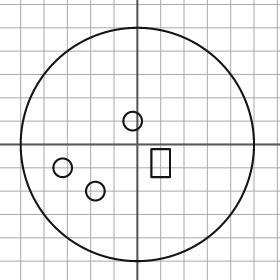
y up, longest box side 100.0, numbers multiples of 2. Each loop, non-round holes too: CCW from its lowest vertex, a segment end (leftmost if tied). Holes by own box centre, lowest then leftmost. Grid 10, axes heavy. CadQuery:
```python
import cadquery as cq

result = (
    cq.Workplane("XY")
    .moveTo(0.0, 0.0)
    .circle(50.0)
    .moveTo(-18.0, -20.0)
    .circle(4.0)
    .moveTo(-32.0, -10.0)
    .circle(4.0)
    .moveTo(6.0, -14.0)
    .lineTo(14.0, -14.0)
    .lineTo(14.0, -2.0)
    .lineTo(6.0, -2.0)
    .close()
    .moveTo(-2.0, 10.0)
    .circle(4.0)
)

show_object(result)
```